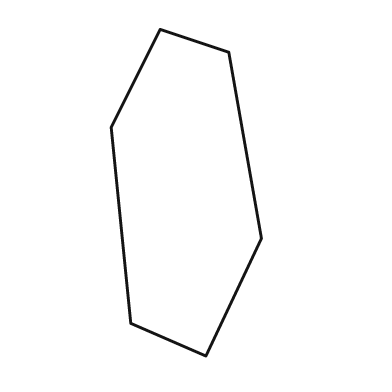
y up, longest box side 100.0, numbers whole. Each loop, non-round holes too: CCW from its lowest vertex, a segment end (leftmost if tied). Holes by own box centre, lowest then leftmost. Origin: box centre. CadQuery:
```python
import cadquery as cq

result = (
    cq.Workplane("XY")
    .moveTo(6.0, -50.0)
    .lineTo(23.0, -14.0)
    .lineTo(13.0, 43.0)
    .lineTo(-8.0, 50.0)
    .lineTo(-23.0, 20.0)
    .lineTo(-17.0, -40.0)
    .close()
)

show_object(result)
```